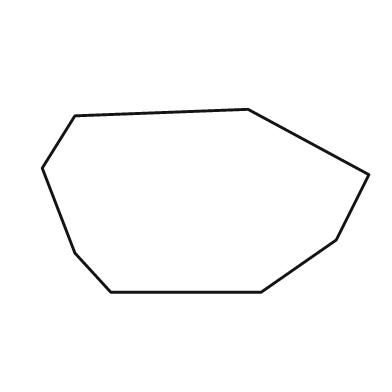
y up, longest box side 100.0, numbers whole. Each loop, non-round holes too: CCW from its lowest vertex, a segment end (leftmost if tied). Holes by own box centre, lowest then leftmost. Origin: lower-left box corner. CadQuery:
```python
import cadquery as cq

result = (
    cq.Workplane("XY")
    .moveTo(21.0, 0.0)
    .lineTo(67.0, 0.0)
    .lineTo(90.0, 16.0)
    .lineTo(100.0, 36.0)
    .lineTo(63.0, 56.0)
    .lineTo(10.0, 54.0)
    .lineTo(0.0, 38.0)
    .lineTo(10.0, 12.0)
    .close()
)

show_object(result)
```